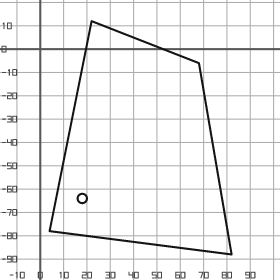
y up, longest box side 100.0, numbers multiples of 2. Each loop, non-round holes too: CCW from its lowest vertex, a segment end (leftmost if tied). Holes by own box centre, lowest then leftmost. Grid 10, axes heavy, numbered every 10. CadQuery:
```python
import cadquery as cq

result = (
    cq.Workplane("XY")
    .moveTo(82.0, -88.0)
    .lineTo(68.0, -6.0)
    .lineTo(22.0, 12.0)
    .lineTo(4.0, -78.0)
    .close()
    .moveTo(18.0, -64.0)
    .circle(2.0)
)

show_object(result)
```